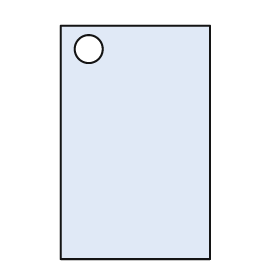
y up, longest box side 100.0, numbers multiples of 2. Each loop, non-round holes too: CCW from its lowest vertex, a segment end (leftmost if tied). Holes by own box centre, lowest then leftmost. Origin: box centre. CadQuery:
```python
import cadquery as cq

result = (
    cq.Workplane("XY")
    .moveTo(-32.0, -50.0)
    .lineTo(32.0, -50.0)
    .lineTo(32.0, 50.0)
    .lineTo(-32.0, 50.0)
    .close()
    .moveTo(-20.0, 40.0)
    .circle(6.0)
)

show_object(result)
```